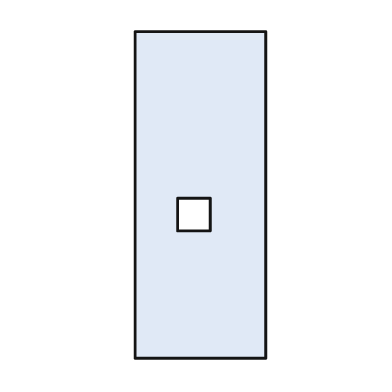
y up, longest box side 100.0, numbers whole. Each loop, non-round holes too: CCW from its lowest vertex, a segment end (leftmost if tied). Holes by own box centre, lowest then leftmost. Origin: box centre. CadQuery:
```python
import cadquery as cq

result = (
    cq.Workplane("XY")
    .moveTo(-20.0, -50.0)
    .lineTo(20.0, -50.0)
    .lineTo(20.0, 50.0)
    .lineTo(-20.0, 50.0)
    .close()
    .moveTo(-7.0, -11.0)
    .lineTo(3.0, -11.0)
    .lineTo(3.0, -1.0)
    .lineTo(-7.0, -1.0)
    .close()
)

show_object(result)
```